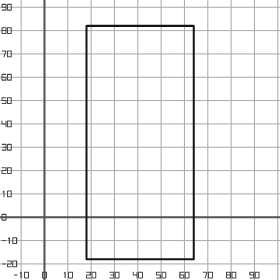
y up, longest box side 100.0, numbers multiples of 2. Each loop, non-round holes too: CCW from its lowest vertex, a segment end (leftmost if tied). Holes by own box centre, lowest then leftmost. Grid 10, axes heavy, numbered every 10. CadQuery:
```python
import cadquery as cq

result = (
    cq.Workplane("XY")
    .moveTo(18.0, -18.0)
    .lineTo(64.0, -18.0)
    .lineTo(64.0, 82.0)
    .lineTo(18.0, 82.0)
    .close()
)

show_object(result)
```